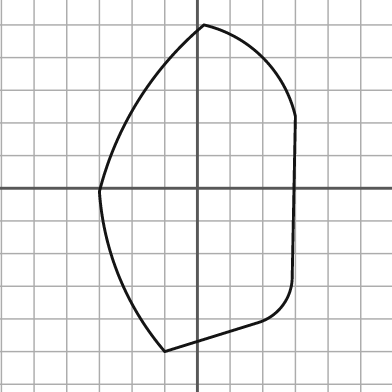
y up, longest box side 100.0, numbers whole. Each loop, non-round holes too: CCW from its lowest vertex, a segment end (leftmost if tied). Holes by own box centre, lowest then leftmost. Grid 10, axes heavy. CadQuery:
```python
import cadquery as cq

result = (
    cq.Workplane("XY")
    .moveTo(-10.0, -50.0)
    .lineTo(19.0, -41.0)
    .threePointArc((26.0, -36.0), (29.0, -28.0))
    .lineTo(30.0, 22.0)
    .threePointArc((20.0, 40.0), (2.0, 50.0))
    .threePointArc((-18.0, 27.0), (-30.0, -1.0))
    .threePointArc((-24.0, -27.0), (-10.0, -50.0))
    .close()
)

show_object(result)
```